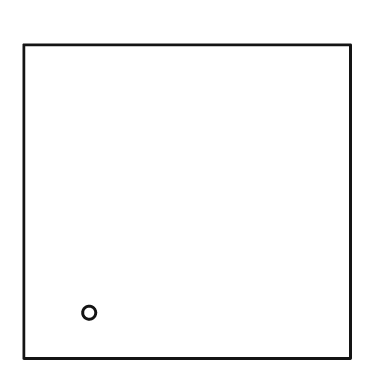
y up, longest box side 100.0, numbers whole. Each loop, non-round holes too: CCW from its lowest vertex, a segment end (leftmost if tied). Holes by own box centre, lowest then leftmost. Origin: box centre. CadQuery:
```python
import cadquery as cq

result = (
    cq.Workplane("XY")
    .moveTo(-50.0, -48.0)
    .lineTo(50.0, -48.0)
    .lineTo(50.0, 48.0)
    .lineTo(-50.0, 48.0)
    .close()
    .moveTo(-30.0, -34.0)
    .circle(2.0)
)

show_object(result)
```